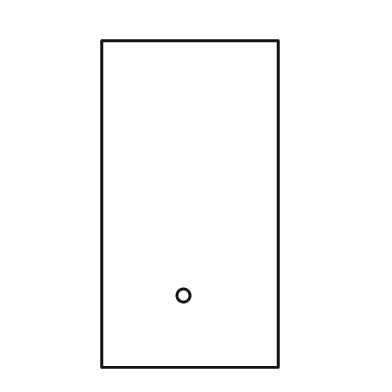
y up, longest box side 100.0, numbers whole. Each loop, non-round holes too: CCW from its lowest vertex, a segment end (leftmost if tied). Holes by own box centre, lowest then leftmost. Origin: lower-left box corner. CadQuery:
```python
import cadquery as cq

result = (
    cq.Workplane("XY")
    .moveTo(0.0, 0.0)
    .lineTo(54.0, 0.0)
    .lineTo(54.0, 100.0)
    .lineTo(0.0, 100.0)
    .close()
    .moveTo(25.0, 22.0)
    .circle(2.0)
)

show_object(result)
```